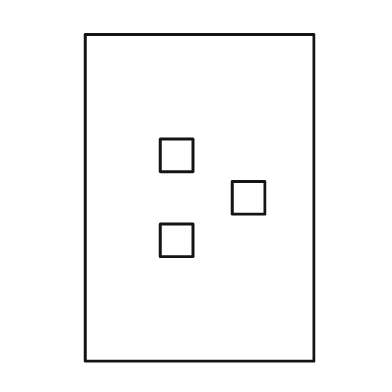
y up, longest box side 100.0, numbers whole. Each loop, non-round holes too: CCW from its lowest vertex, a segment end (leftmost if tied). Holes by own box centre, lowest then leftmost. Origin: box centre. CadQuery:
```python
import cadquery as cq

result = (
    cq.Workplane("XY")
    .moveTo(-35.0, -50.0)
    .lineTo(35.0, -50.0)
    .lineTo(35.0, 50.0)
    .lineTo(-35.0, 50.0)
    .close()
    .moveTo(-12.0, -18.0)
    .lineTo(-2.0, -18.0)
    .lineTo(-2.0, -8.0)
    .lineTo(-12.0, -8.0)
    .close()
    .moveTo(10.0, -5.0)
    .lineTo(20.0, -5.0)
    .lineTo(20.0, 5.0)
    .lineTo(10.0, 5.0)
    .close()
    .moveTo(-12.0, 8.0)
    .lineTo(-2.0, 8.0)
    .lineTo(-2.0, 18.0)
    .lineTo(-12.0, 18.0)
    .close()
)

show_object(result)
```